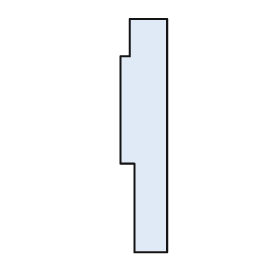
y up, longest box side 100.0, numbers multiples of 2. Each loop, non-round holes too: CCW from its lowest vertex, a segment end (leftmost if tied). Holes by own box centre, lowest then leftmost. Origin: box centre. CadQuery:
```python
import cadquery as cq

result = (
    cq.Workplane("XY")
    .moveTo(-4.0, -50.0)
    .lineTo(10.0, -50.0)
    .lineTo(10.0, 50.0)
    .lineTo(-6.0, 50.0)
    .lineTo(-6.0, 34.0)
    .lineTo(-10.0, 34.0)
    .lineTo(-10.0, -12.0)
    .lineTo(-4.0, -12.0)
    .close()
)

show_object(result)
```